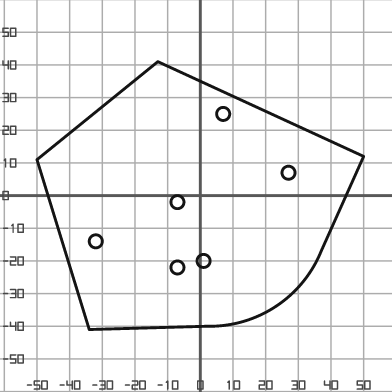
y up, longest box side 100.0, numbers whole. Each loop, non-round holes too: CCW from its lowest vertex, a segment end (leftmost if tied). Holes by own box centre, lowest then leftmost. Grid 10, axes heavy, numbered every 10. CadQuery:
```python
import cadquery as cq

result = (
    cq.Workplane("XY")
    .moveTo(-34.0, -41.0)
    .lineTo(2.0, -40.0)
    .threePointArc((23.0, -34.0), (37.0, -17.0))
    .lineTo(50.0, 12.0)
    .lineTo(-13.0, 41.0)
    .lineTo(-50.0, 11.0)
    .close()
    .moveTo(-7.0, -22.0)
    .circle(2.0)
    .moveTo(1.0, -20.0)
    .circle(2.0)
    .moveTo(-32.0, -14.0)
    .circle(2.0)
    .moveTo(-7.0, -2.0)
    .circle(2.0)
    .moveTo(27.0, 7.0)
    .circle(2.0)
    .moveTo(7.0, 25.0)
    .circle(2.0)
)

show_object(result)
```